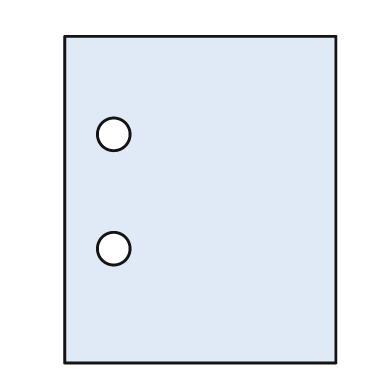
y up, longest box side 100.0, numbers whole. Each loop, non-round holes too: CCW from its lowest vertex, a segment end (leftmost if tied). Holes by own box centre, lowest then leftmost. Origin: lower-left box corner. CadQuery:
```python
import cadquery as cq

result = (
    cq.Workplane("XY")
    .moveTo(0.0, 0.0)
    .lineTo(83.0, 0.0)
    .lineTo(83.0, 100.0)
    .lineTo(0.0, 100.0)
    .close()
    .moveTo(15.0, 35.0)
    .circle(5.0)
    .moveTo(15.0, 70.0)
    .circle(5.0)
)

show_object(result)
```